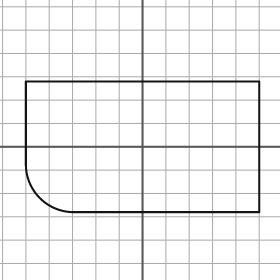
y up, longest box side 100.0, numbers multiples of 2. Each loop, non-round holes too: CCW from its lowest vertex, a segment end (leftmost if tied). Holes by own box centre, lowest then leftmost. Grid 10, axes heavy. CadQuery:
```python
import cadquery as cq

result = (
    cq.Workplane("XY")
    .moveTo(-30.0, -28.0)
    .lineTo(50.0, -28.0)
    .lineTo(50.0, 28.0)
    .lineTo(-50.0, 28.0)
    .lineTo(-50.0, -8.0)
    .threePointArc((-44.0, -22.0), (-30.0, -28.0))
    .close()
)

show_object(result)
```